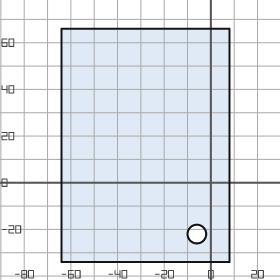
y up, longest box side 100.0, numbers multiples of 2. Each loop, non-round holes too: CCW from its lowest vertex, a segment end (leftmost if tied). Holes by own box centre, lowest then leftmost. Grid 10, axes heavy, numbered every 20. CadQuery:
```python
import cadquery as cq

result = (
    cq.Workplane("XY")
    .moveTo(-64.0, -34.0)
    .lineTo(8.0, -34.0)
    .lineTo(8.0, 66.0)
    .lineTo(-64.0, 66.0)
    .close()
    .moveTo(-6.0, -22.0)
    .circle(4.0)
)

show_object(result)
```